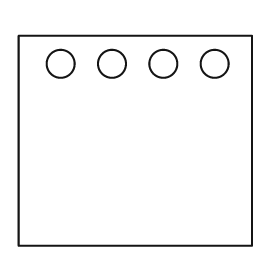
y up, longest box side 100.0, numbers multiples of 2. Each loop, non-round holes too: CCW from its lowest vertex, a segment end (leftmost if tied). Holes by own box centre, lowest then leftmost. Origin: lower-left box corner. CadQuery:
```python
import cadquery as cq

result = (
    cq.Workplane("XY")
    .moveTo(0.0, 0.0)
    .lineTo(100.0, 0.0)
    .lineTo(100.0, 90.0)
    .lineTo(0.0, 90.0)
    .close()
    .moveTo(18.0, 78.0)
    .circle(6.0)
    .moveTo(40.0, 78.0)
    .circle(6.0)
    .moveTo(62.0, 78.0)
    .circle(6.0)
    .moveTo(84.0, 78.0)
    .circle(6.0)
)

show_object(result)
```